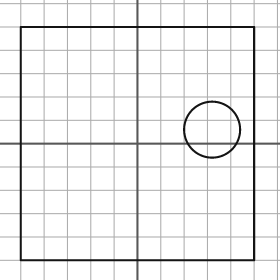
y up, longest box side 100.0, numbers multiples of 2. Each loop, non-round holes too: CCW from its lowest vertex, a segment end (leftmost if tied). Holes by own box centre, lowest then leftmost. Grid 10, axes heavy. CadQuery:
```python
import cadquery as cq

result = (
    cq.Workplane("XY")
    .moveTo(-50.0, -50.0)
    .lineTo(50.0, -50.0)
    .lineTo(50.0, 50.0)
    .lineTo(-50.0, 50.0)
    .close()
    .moveTo(32.0, 6.0)
    .circle(12.0)
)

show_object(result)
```